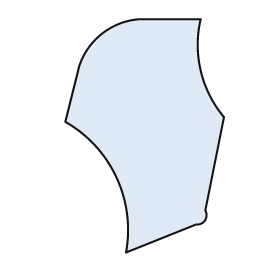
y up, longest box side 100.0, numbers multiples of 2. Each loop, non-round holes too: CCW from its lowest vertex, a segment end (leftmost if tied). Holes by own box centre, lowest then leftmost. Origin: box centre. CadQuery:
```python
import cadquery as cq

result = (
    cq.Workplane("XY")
    .moveTo(-8.0, -50.0)
    .lineTo(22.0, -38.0)
    .threePointArc((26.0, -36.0), (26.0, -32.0))
    .lineTo(34.0, 8.0)
    .threePointArc((24.0, 28.0), (24.0, 50.0))
    .lineTo(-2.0, 50.0)
    .threePointArc((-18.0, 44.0), (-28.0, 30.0))
    .lineTo(-34.0, 6.0)
    .threePointArc((-12.0, -18.0), (-8.0, -50.0))
    .close()
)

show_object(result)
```